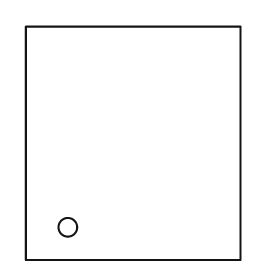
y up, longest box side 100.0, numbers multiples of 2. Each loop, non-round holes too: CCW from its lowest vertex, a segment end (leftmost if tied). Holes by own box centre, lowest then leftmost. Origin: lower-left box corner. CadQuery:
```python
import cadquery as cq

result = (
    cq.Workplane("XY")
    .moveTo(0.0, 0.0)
    .lineTo(92.0, 0.0)
    .lineTo(92.0, 100.0)
    .lineTo(0.0, 100.0)
    .close()
    .moveTo(18.0, 14.0)
    .circle(4.0)
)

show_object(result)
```